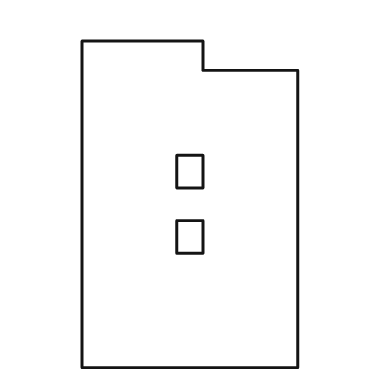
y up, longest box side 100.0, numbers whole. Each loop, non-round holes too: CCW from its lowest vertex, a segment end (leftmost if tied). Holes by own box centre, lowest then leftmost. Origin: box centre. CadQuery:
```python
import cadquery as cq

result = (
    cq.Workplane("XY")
    .moveTo(-33.0, -50.0)
    .lineTo(33.0, -50.0)
    .lineTo(33.0, 41.0)
    .lineTo(4.0, 41.0)
    .lineTo(4.0, 50.0)
    .lineTo(-33.0, 50.0)
    .close()
    .moveTo(-4.0, -15.0)
    .lineTo(4.0, -15.0)
    .lineTo(4.0, -5.0)
    .lineTo(-4.0, -5.0)
    .close()
    .moveTo(-4.0, 5.0)
    .lineTo(4.0, 5.0)
    .lineTo(4.0, 15.0)
    .lineTo(-4.0, 15.0)
    .close()
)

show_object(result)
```